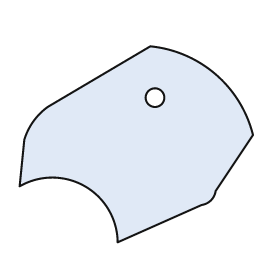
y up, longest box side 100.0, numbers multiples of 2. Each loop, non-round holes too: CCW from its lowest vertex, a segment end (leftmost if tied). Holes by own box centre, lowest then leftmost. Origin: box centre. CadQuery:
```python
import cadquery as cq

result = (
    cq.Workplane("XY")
    .moveTo(-8.0, -42.0)
    .lineTo(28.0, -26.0)
    .threePointArc((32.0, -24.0), (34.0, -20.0))
    .lineTo(50.0, 4.0)
    .threePointArc((34.0, 30.0), (6.0, 42.0))
    .lineTo(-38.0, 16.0)
    .threePointArc((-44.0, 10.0), (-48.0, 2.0))
    .lineTo(-50.0, -18.0)
    .threePointArc((-22.0, -18.0), (-8.0, -42.0))
    .close()
    .moveTo(8.0, 20.0)
    .circle(4.0)
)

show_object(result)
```